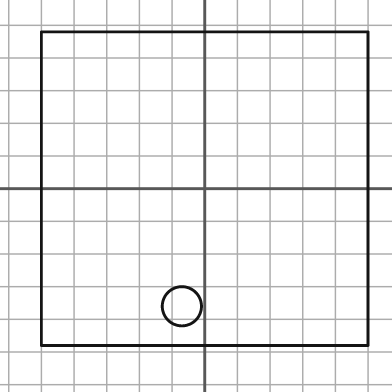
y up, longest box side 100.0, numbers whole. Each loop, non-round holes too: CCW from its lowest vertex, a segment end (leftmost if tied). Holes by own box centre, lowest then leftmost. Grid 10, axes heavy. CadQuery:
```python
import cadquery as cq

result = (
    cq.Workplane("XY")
    .moveTo(-50.0, -48.0)
    .lineTo(50.0, -48.0)
    .lineTo(50.0, 48.0)
    .lineTo(-50.0, 48.0)
    .close()
    .moveTo(-7.0, -36.0)
    .circle(6.0)
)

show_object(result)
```